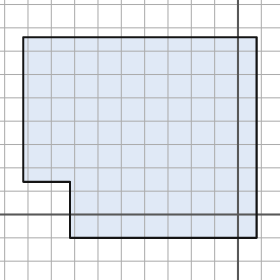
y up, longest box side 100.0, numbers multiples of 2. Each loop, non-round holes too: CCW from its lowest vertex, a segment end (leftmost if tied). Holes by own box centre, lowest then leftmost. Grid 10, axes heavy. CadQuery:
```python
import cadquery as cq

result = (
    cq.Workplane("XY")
    .moveTo(-72.0, -10.0)
    .lineTo(8.0, -10.0)
    .lineTo(8.0, 76.0)
    .lineTo(-92.0, 76.0)
    .lineTo(-92.0, 14.0)
    .lineTo(-72.0, 14.0)
    .close()
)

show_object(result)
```